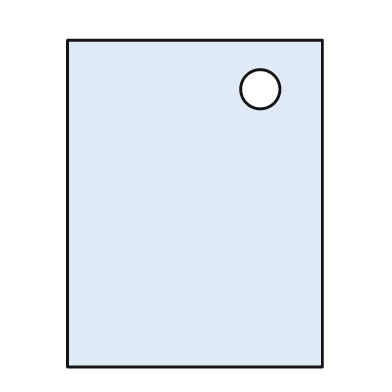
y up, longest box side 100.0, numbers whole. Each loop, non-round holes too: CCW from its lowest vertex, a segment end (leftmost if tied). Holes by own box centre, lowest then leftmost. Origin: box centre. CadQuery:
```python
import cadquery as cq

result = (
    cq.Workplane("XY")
    .moveTo(-39.0, -50.0)
    .lineTo(39.0, -50.0)
    .lineTo(39.0, 50.0)
    .lineTo(-39.0, 50.0)
    .close()
    .moveTo(20.0, 35.0)
    .circle(6.0)
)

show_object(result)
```